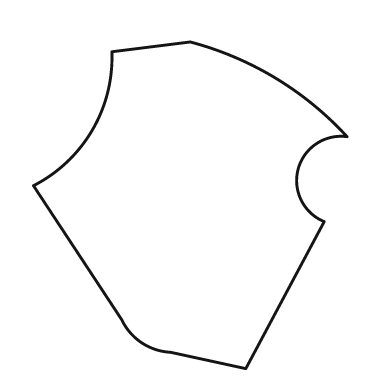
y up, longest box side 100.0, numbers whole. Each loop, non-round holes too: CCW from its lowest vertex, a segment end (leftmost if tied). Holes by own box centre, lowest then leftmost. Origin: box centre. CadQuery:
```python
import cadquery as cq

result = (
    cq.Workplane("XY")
    .moveTo(17.0, -50.0)
    .lineTo(41.0, -5.0)
    .threePointArc((33.0, 11.0), (48.0, 21.0))
    .threePointArc((26.0, 39.0), (0.0, 50.0))
    .lineTo(-24.0, 47.0)
    .threePointArc((-30.0, 23.0), (-48.0, 6.0))
    .lineTo(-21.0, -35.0)
    .threePointArc((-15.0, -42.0), (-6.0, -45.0))
    .close()
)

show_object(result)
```